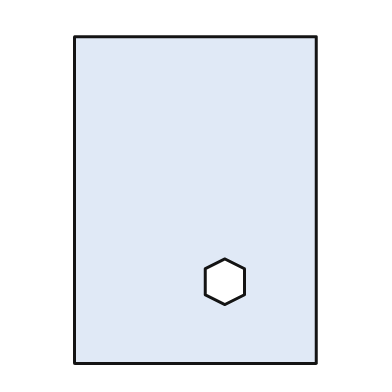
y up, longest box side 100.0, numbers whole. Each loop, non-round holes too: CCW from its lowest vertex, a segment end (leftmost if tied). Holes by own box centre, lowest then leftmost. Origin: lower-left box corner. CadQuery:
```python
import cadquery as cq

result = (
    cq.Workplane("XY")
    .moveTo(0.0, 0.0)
    .lineTo(74.0, 0.0)
    .lineTo(74.0, 100.0)
    .lineTo(0.0, 100.0)
    .close()
    .moveTo(46.0, 18.0)
    .lineTo(52.0, 21.0)
    .lineTo(52.0, 29.0)
    .lineTo(46.0, 32.0)
    .lineTo(40.0, 29.0)
    .lineTo(40.0, 21.0)
    .close()
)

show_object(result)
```